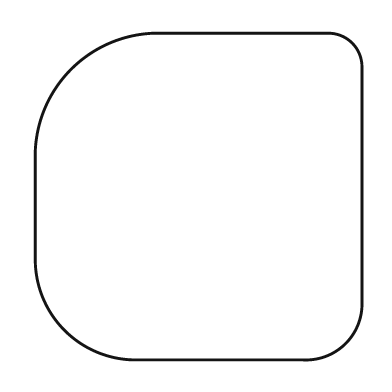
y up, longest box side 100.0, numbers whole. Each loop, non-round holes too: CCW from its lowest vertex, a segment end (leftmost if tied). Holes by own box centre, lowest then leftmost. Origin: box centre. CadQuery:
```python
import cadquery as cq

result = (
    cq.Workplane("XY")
    .moveTo(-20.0, -50.0)
    .lineTo(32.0, -50.0)
    .threePointArc((45.0, -45.0), (50.0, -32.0))
    .lineTo(50.0, 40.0)
    .threePointArc((47.0, 47.0), (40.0, 50.0))
    .lineTo(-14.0, 50.0)
    .threePointArc((-39.0, 39.0), (-50.0, 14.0))
    .lineTo(-50.0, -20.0)
    .threePointArc((-41.0, -41.0), (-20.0, -50.0))
    .close()
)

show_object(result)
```